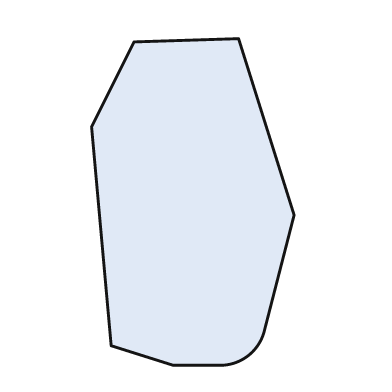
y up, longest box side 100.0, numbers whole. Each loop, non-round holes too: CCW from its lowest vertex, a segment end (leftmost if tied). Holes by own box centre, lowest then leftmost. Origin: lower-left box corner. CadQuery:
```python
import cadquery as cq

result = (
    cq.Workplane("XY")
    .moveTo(25.0, 0.0)
    .lineTo(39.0, 0.0)
    .threePointArc((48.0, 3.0), (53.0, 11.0))
    .lineTo(62.0, 46.0)
    .lineTo(45.0, 100.0)
    .lineTo(13.0, 99.0)
    .lineTo(0.0, 73.0)
    .lineTo(6.0, 6.0)
    .close()
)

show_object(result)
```